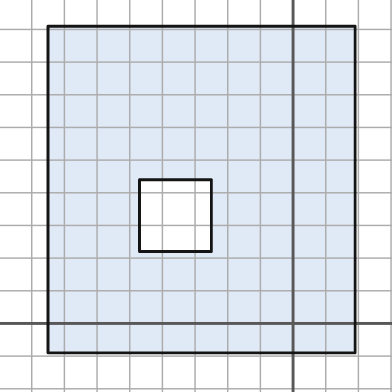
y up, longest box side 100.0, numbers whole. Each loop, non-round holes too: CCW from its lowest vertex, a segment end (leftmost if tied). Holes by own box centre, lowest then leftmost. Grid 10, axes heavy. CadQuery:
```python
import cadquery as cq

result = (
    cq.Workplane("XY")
    .moveTo(-75.0, -9.0)
    .lineTo(19.0, -9.0)
    .lineTo(19.0, 91.0)
    .lineTo(-75.0, 91.0)
    .close()
    .moveTo(-47.0, 22.0)
    .lineTo(-25.0, 22.0)
    .lineTo(-25.0, 44.0)
    .lineTo(-47.0, 44.0)
    .close()
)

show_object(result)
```